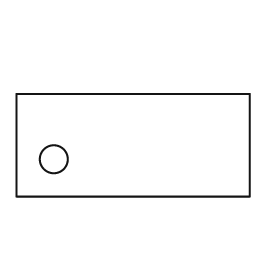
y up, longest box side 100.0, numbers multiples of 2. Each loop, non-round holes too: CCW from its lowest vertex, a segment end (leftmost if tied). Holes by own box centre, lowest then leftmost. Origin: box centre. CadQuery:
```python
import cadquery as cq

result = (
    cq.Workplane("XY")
    .moveTo(-50.0, -22.0)
    .lineTo(50.0, -22.0)
    .lineTo(50.0, 22.0)
    .lineTo(-50.0, 22.0)
    .close()
    .moveTo(-34.0, -6.0)
    .circle(6.0)
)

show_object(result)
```